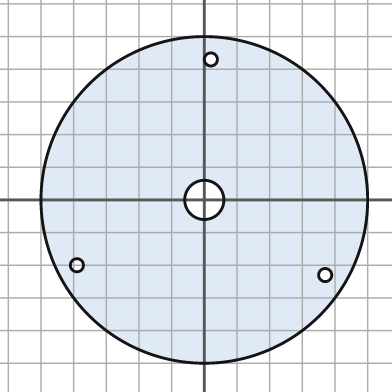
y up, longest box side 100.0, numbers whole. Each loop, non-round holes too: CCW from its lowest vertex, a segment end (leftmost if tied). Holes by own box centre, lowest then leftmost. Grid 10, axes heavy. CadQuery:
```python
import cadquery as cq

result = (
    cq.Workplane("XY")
    .moveTo(0.0, 0.0)
    .circle(50.0)
    .moveTo(37.0, -23.0)
    .circle(2.0)
    .moveTo(-39.0, -20.0)
    .circle(2.0)
    .moveTo(0.0, 0.0)
    .circle(6.0)
    .moveTo(2.0, 43.0)
    .circle(2.0)
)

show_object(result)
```